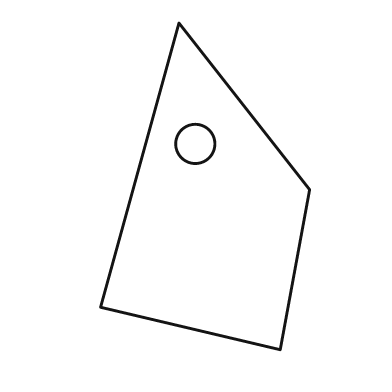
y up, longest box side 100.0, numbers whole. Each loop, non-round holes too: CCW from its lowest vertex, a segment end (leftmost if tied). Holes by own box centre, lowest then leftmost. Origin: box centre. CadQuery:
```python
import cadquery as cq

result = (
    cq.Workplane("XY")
    .moveTo(23.0, -50.0)
    .lineTo(32.0, -1.0)
    .lineTo(-8.0, 50.0)
    .lineTo(-32.0, -37.0)
    .close()
    .moveTo(-3.0, 13.0)
    .circle(6.0)
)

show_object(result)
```